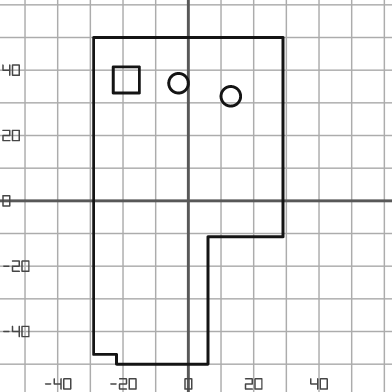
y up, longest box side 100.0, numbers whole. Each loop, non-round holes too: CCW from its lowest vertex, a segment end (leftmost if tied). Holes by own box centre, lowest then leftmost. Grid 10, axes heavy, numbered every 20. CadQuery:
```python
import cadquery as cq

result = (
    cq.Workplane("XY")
    .moveTo(-22.0, -50.0)
    .lineTo(6.0, -50.0)
    .lineTo(6.0, -11.0)
    .lineTo(29.0, -11.0)
    .lineTo(29.0, 50.0)
    .lineTo(-29.0, 50.0)
    .lineTo(-29.0, -47.0)
    .lineTo(-22.0, -47.0)
    .close()
    .moveTo(13.0, 32.0)
    .circle(3.0)
    .moveTo(-3.0, 36.0)
    .circle(3.0)
    .moveTo(-23.0, 33.0)
    .lineTo(-15.0, 33.0)
    .lineTo(-15.0, 41.0)
    .lineTo(-23.0, 41.0)
    .close()
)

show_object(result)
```